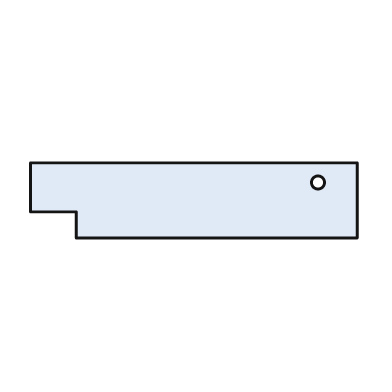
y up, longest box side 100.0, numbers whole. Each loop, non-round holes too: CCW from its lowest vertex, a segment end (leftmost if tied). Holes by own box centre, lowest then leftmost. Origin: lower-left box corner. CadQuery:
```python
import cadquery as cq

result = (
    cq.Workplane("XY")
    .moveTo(14.0, 0.0)
    .lineTo(100.0, 0.0)
    .lineTo(100.0, 23.0)
    .lineTo(0.0, 23.0)
    .lineTo(0.0, 8.0)
    .lineTo(14.0, 8.0)
    .close()
    .moveTo(88.0, 17.0)
    .circle(2.0)
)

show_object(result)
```